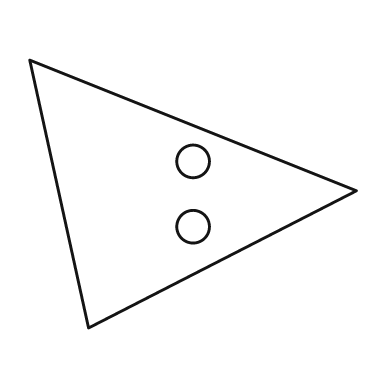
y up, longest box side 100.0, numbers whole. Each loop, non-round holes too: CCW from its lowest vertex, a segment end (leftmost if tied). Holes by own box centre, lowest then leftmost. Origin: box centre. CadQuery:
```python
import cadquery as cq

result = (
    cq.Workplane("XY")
    .moveTo(-32.0, -41.0)
    .lineTo(50.0, 1.0)
    .lineTo(-50.0, 41.0)
    .close()
    .moveTo(0.0, -10.0)
    .circle(5.0)
    .moveTo(0.0, 10.0)
    .circle(5.0)
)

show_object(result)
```